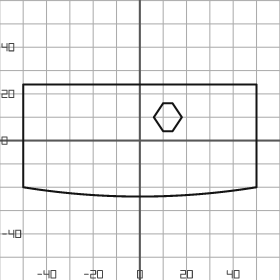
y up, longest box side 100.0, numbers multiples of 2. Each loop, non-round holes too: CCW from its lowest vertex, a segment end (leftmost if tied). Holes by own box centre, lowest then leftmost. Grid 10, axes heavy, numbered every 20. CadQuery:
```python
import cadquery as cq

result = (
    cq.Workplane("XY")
    .moveTo(-50.0, -20.0)
    .threePointArc((0.0, -24.0), (50.0, -20.0))
    .lineTo(50.0, 24.0)
    .lineTo(-50.0, 24.0)
    .close()
    .moveTo(10.0, 4.0)
    .lineTo(14.0, 4.0)
    .lineTo(18.0, 10.0)
    .lineTo(14.0, 16.0)
    .lineTo(10.0, 16.0)
    .lineTo(6.0, 10.0)
    .close()
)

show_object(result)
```